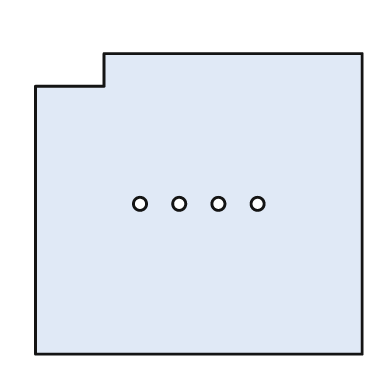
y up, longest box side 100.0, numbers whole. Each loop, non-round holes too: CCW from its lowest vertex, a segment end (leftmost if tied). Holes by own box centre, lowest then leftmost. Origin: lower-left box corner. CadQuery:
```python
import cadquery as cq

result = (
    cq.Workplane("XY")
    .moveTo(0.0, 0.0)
    .lineTo(100.0, 0.0)
    .lineTo(100.0, 92.0)
    .lineTo(21.0, 92.0)
    .lineTo(21.0, 82.0)
    .lineTo(0.0, 82.0)
    .close()
    .moveTo(32.0, 46.0)
    .circle(2.0)
    .moveTo(44.0, 46.0)
    .circle(2.0)
    .moveTo(56.0, 46.0)
    .circle(2.0)
    .moveTo(68.0, 46.0)
    .circle(2.0)
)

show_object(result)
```